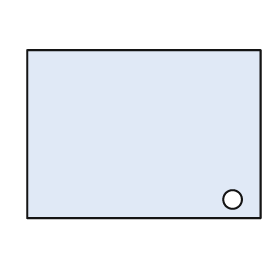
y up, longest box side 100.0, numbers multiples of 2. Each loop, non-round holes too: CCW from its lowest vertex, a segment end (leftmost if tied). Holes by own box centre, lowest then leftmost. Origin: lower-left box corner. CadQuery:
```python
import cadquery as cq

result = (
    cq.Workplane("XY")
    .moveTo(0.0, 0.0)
    .lineTo(100.0, 0.0)
    .lineTo(100.0, 72.0)
    .lineTo(0.0, 72.0)
    .close()
    .moveTo(88.0, 8.0)
    .circle(4.0)
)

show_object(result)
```